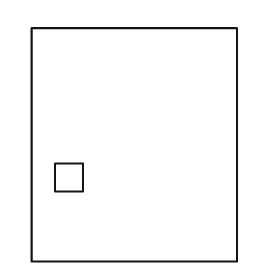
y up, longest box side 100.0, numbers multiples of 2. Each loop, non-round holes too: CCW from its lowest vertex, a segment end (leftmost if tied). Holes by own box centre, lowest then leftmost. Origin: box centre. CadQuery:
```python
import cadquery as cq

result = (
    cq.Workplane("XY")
    .moveTo(-44.0, -50.0)
    .lineTo(44.0, -50.0)
    .lineTo(44.0, 50.0)
    .lineTo(-44.0, 50.0)
    .close()
    .moveTo(-34.0, -20.0)
    .lineTo(-22.0, -20.0)
    .lineTo(-22.0, -8.0)
    .lineTo(-34.0, -8.0)
    .close()
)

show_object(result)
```